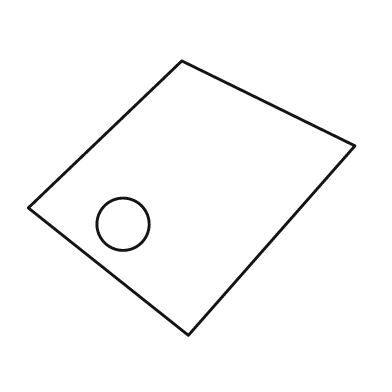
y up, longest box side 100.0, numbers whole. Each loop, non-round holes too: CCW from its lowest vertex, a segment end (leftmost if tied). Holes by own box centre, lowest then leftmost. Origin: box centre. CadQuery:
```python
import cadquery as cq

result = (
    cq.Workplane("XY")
    .moveTo(-1.0, -42.0)
    .lineTo(50.0, 16.0)
    .lineTo(-3.0, 42.0)
    .lineTo(-50.0, -3.0)
    .close()
    .moveTo(-21.0, -8.0)
    .circle(8.0)
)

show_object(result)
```